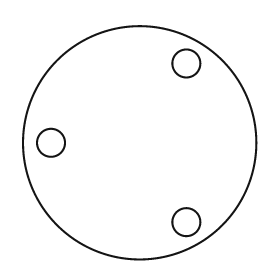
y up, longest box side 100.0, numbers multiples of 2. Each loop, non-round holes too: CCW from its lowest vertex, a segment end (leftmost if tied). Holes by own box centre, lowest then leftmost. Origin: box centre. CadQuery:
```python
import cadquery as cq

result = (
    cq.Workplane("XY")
    .moveTo(0.0, 0.0)
    .circle(50.0)
    .moveTo(20.0, -34.0)
    .circle(6.0)
    .moveTo(-38.0, 0.0)
    .circle(6.0)
    .moveTo(20.0, 34.0)
    .circle(6.0)
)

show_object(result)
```